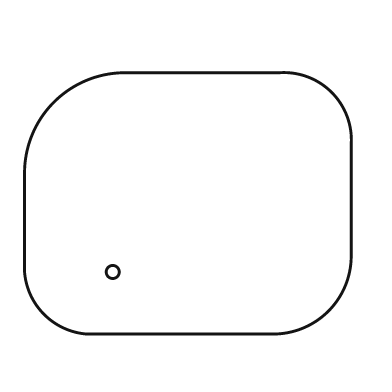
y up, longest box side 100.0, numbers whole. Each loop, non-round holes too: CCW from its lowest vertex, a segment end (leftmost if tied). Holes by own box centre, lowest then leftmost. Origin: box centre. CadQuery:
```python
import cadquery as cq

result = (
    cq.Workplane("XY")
    .moveTo(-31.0, -40.0)
    .lineTo(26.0, -40.0)
    .threePointArc((43.0, -33.0), (50.0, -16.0))
    .lineTo(50.0, 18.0)
    .threePointArc((44.0, 34.0), (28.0, 40.0))
    .lineTo(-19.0, 40.0)
    .threePointArc((-41.0, 31.0), (-50.0, 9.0))
    .lineTo(-50.0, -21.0)
    .threePointArc((-44.0, -34.0), (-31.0, -40.0))
    .close()
    .moveTo(-23.0, -21.0)
    .circle(2.0)
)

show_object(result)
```